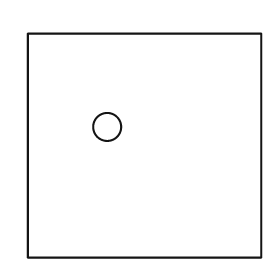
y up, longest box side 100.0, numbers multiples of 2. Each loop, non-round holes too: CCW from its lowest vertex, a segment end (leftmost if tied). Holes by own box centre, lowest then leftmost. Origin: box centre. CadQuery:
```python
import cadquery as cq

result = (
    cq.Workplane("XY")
    .moveTo(-50.0, -48.0)
    .lineTo(50.0, -48.0)
    .lineTo(50.0, 48.0)
    .lineTo(-50.0, 48.0)
    .close()
    .moveTo(-16.0, 8.0)
    .circle(6.0)
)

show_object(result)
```